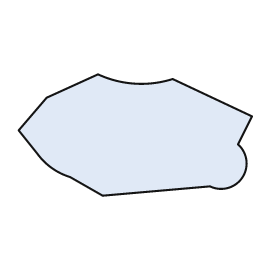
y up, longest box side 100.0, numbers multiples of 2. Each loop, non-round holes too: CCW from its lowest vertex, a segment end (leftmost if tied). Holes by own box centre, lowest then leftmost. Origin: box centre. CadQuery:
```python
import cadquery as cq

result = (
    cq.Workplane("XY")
    .moveTo(-14.0, -26.0)
    .lineTo(32.0, -22.0)
    .threePointArc((46.0, -18.0), (44.0, -4.0))
    .lineTo(50.0, 8.0)
    .lineTo(16.0, 24.0)
    .threePointArc((0.0, 22.0), (-16.0, 26.0))
    .lineTo(-38.0, 16.0)
    .lineTo(-50.0, 2.0)
    .lineTo(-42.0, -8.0)
    .threePointArc((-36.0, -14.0), (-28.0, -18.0))
    .close()
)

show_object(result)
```